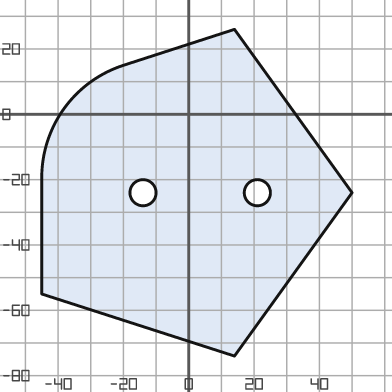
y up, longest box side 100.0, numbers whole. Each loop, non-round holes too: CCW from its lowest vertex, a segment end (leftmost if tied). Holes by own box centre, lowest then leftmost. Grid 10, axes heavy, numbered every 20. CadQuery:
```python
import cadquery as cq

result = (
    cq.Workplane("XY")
    .moveTo(14.0, -74.0)
    .lineTo(50.0, -24.0)
    .lineTo(14.0, 26.0)
    .lineTo(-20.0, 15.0)
    .threePointArc((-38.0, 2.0), (-45.0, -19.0))
    .lineTo(-45.0, -55.0)
    .close()
    .moveTo(-14.0, -24.0)
    .circle(4.0)
    .moveTo(21.0, -24.0)
    .circle(4.0)
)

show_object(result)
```